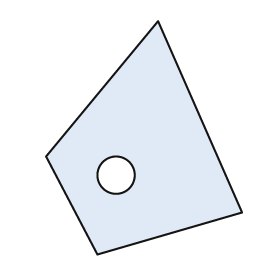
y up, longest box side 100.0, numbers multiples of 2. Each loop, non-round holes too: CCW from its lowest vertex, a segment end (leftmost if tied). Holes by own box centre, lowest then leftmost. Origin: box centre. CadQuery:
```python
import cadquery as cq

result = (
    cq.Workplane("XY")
    .moveTo(-20.0, -50.0)
    .lineTo(42.0, -32.0)
    .lineTo(6.0, 50.0)
    .lineTo(-42.0, -8.0)
    .close()
    .moveTo(-12.0, -16.0)
    .circle(8.0)
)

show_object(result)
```